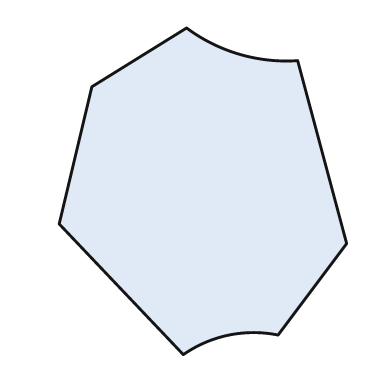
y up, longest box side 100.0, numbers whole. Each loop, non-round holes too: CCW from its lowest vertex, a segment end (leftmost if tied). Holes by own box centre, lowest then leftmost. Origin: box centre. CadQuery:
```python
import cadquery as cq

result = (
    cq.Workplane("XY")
    .moveTo(-6.0, -50.0)
    .threePointArc((8.0, -44.0), (23.0, -44.0))
    .lineTo(44.0, -16.0)
    .lineTo(29.0, 40.0)
    .threePointArc((11.0, 42.0), (-5.0, 50.0))
    .lineTo(-34.0, 32.0)
    .lineTo(-44.0, -10.0)
    .close()
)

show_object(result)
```